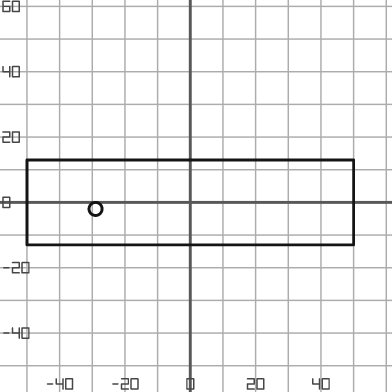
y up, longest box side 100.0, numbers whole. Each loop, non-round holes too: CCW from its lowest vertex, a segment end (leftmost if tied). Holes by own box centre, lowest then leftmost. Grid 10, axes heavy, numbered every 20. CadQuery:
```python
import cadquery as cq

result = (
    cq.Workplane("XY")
    .moveTo(-50.0, -13.0)
    .lineTo(50.0, -13.0)
    .lineTo(50.0, 13.0)
    .lineTo(-50.0, 13.0)
    .close()
    .moveTo(-29.0, -2.0)
    .circle(2.0)
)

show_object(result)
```